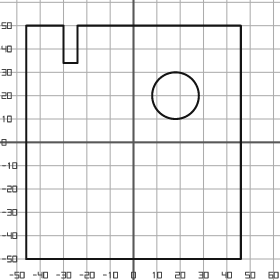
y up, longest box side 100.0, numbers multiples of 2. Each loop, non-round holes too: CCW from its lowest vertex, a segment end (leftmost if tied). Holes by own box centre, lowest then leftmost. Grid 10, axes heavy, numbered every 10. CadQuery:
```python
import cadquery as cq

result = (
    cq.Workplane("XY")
    .moveTo(-46.0, -50.0)
    .lineTo(46.0, -50.0)
    .lineTo(46.0, 50.0)
    .lineTo(-24.0, 50.0)
    .lineTo(-24.0, 34.0)
    .lineTo(-30.0, 34.0)
    .lineTo(-30.0, 50.0)
    .lineTo(-46.0, 50.0)
    .close()
    .moveTo(18.0, 20.0)
    .circle(10.0)
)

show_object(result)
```